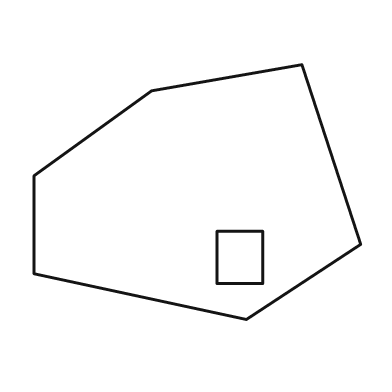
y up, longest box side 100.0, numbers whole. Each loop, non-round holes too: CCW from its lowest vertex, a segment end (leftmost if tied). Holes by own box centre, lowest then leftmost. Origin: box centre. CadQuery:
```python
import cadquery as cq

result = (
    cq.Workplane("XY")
    .moveTo(15.0, -39.0)
    .lineTo(50.0, -16.0)
    .lineTo(32.0, 39.0)
    .lineTo(-14.0, 31.0)
    .lineTo(-50.0, 5.0)
    .lineTo(-50.0, -25.0)
    .close()
    .moveTo(6.0, -28.0)
    .lineTo(20.0, -28.0)
    .lineTo(20.0, -12.0)
    .lineTo(6.0, -12.0)
    .close()
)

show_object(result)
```